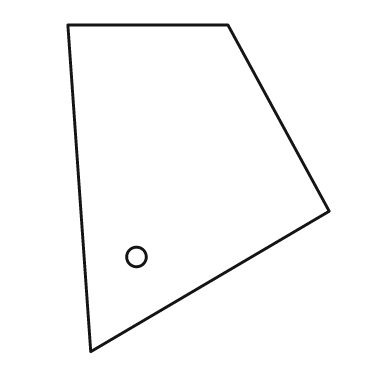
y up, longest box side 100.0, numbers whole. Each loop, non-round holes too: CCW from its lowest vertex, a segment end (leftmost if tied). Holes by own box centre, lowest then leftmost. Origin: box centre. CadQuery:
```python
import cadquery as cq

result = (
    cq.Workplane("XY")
    .moveTo(-33.0, -50.0)
    .lineTo(40.0, -7.0)
    .lineTo(9.0, 50.0)
    .lineTo(-40.0, 50.0)
    .close()
    .moveTo(-19.0, -21.0)
    .circle(3.0)
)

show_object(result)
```